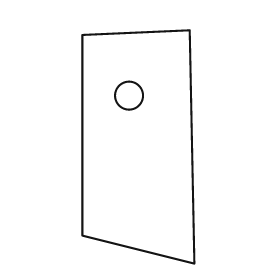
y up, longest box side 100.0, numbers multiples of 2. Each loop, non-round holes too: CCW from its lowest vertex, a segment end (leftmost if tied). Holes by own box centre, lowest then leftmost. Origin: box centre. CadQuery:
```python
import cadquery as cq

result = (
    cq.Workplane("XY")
    .moveTo(24.0, -50.0)
    .lineTo(22.0, 50.0)
    .lineTo(-24.0, 48.0)
    .lineTo(-24.0, -38.0)
    .close()
    .moveTo(-4.0, 22.0)
    .circle(6.0)
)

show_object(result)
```